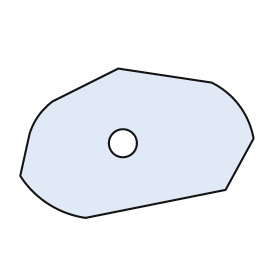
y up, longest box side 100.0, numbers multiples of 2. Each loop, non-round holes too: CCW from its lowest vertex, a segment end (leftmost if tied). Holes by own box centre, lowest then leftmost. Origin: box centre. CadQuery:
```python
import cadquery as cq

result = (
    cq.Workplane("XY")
    .moveTo(-22.0, -32.0)
    .lineTo(38.0, -20.0)
    .lineTo(50.0, 2.0)
    .threePointArc((44.0, 16.0), (32.0, 26.0))
    .lineTo(-8.0, 32.0)
    .lineTo(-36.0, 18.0)
    .threePointArc((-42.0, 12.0), (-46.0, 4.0))
    .lineTo(-50.0, -14.0)
    .threePointArc((-38.0, -26.0), (-22.0, -32.0))
    .close()
    .moveTo(-6.0, 0.0)
    .circle(6.0)
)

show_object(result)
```